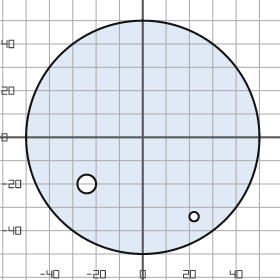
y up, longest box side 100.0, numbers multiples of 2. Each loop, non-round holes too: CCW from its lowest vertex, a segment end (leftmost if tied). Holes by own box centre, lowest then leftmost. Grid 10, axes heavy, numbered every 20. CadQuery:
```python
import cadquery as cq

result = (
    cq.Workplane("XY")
    .moveTo(0.0, 0.0)
    .circle(50.0)
    .moveTo(22.0, -34.0)
    .circle(2.0)
    .moveTo(-24.0, -20.0)
    .circle(4.0)
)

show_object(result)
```